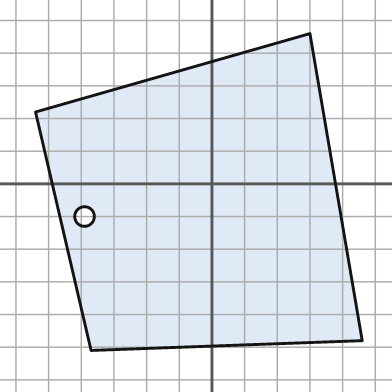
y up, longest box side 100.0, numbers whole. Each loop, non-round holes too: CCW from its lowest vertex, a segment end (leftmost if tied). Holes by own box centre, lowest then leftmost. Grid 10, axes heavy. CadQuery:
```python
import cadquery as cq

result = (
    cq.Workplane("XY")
    .moveTo(-37.0, -51.0)
    .lineTo(46.0, -48.0)
    .lineTo(30.0, 46.0)
    .lineTo(-54.0, 22.0)
    .close()
    .moveTo(-39.0, -10.0)
    .circle(3.0)
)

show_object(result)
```